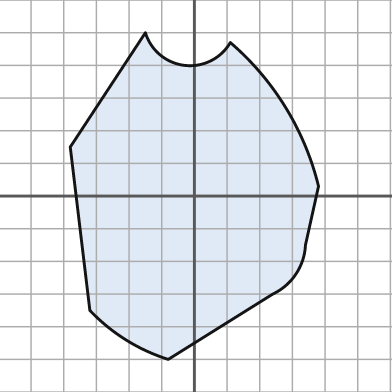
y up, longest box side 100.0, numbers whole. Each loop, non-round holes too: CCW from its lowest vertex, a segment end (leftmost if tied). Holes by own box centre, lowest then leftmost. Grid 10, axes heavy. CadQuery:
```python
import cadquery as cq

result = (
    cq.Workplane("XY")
    .moveTo(-8.0, -50.0)
    .lineTo(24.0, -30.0)
    .threePointArc((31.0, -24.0), (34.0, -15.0))
    .lineTo(38.0, 3.0)
    .threePointArc((28.0, 27.0), (11.0, 47.0))
    .threePointArc((-3.0, 40.0), (-15.0, 50.0))
    .lineTo(-38.0, 15.0)
    .lineTo(-32.0, -35.0)
    .threePointArc((-21.0, -44.0), (-8.0, -50.0))
    .close()
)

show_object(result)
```